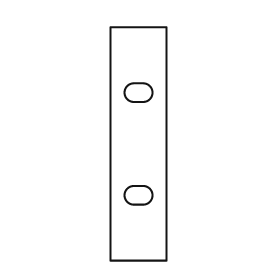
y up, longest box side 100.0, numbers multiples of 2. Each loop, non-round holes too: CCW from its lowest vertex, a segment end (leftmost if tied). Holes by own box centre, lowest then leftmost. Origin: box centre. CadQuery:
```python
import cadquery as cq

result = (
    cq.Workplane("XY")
    .moveTo(-12.0, -50.0)
    .lineTo(12.0, -50.0)
    .lineTo(12.0, 50.0)
    .lineTo(-12.0, 50.0)
    .close()
    .moveTo(-2.0, -26.0)
    .lineTo(2.0, -26.0)
    .threePointArc((6.0, -22.0), (2.0, -18.0))
    .lineTo(-2.0, -18.0)
    .threePointArc((-6.0, -22.0), (-2.0, -26.0))
    .close()
    .moveTo(-2.0, 18.0)
    .lineTo(2.0, 18.0)
    .threePointArc((6.0, 22.0), (2.0, 26.0))
    .lineTo(-2.0, 26.0)
    .threePointArc((-6.0, 22.0), (-2.0, 18.0))
    .close()
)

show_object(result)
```